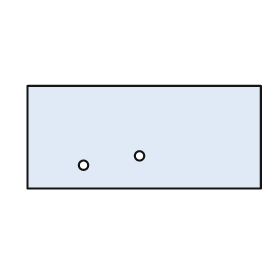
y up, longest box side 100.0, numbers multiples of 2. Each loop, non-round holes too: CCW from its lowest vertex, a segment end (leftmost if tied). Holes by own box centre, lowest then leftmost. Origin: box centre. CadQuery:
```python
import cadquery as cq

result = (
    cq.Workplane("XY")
    .moveTo(-50.0, -22.0)
    .lineTo(50.0, -22.0)
    .lineTo(50.0, 22.0)
    .lineTo(-50.0, 22.0)
    .close()
    .moveTo(-26.0, -12.0)
    .circle(2.0)
    .moveTo(-2.0, -8.0)
    .circle(2.0)
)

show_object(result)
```